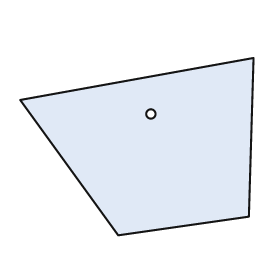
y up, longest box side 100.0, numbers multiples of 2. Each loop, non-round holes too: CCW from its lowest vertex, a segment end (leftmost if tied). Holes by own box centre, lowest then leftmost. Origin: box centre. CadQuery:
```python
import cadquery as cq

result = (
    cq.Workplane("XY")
    .moveTo(-8.0, -38.0)
    .lineTo(48.0, -30.0)
    .lineTo(50.0, 38.0)
    .lineTo(-50.0, 20.0)
    .close()
    .moveTo(6.0, 14.0)
    .circle(2.0)
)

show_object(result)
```